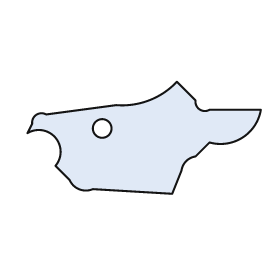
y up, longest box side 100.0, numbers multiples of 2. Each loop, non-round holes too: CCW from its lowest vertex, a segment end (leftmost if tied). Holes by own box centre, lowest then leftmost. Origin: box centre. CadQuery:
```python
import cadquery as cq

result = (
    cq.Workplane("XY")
    .moveTo(12.0, -24.0)
    .lineTo(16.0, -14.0)
    .threePointArc((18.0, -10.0), (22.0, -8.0))
    .lineTo(28.0, -2.0)
    .threePointArc((42.0, 0.0), (50.0, 12.0))
    .lineTo(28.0, 12.0)
    .threePointArc((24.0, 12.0), (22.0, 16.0))
    .lineTo(14.0, 24.0)
    .threePointArc((2.0, 16.0), (-12.0, 14.0))
    .lineTo(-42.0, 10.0)
    .threePointArc((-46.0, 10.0), (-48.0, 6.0))
    .lineTo(-50.0, 2.0)
    .threePointArc((-38.0, 0.0), (-38.0, -12.0))
    .lineTo(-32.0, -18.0)
    .threePointArc((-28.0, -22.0), (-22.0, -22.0))
    .close()
    .moveTo(-18.0, 4.0)
    .circle(4.0)
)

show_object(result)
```